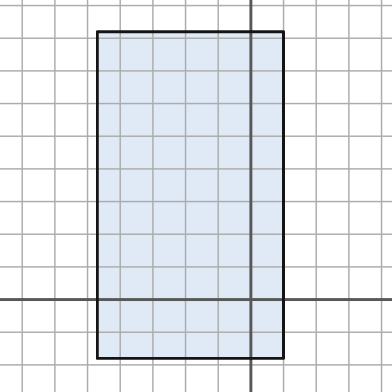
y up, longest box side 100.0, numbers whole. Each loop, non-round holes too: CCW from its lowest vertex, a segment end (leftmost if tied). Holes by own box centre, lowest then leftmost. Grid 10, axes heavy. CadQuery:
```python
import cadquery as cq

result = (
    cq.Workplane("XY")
    .moveTo(-47.0, -18.0)
    .lineTo(10.0, -18.0)
    .lineTo(10.0, 82.0)
    .lineTo(-47.0, 82.0)
    .close()
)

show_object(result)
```